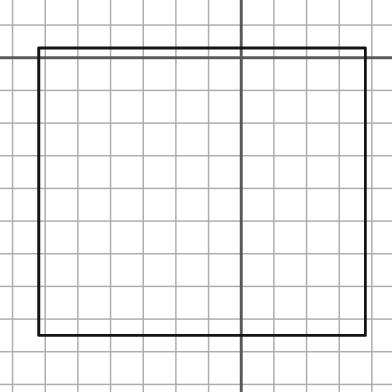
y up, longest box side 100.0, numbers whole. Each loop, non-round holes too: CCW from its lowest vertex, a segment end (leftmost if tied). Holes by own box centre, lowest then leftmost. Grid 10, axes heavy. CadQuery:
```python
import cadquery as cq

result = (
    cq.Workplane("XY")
    .moveTo(-62.0, -85.0)
    .lineTo(38.0, -85.0)
    .lineTo(38.0, 3.0)
    .lineTo(-62.0, 3.0)
    .close()
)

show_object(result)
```